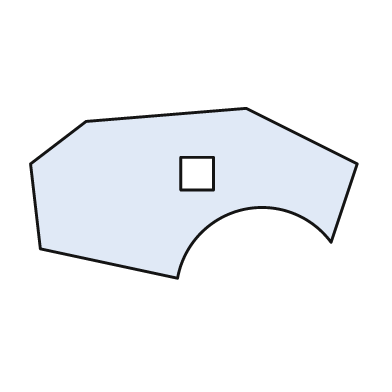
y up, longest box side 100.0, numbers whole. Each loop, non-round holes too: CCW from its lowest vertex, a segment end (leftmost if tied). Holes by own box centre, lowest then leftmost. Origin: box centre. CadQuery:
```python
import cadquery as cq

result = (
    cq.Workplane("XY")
    .moveTo(-5.0, -26.0)
    .threePointArc((15.0, -5.0), (42.0, -15.0))
    .lineTo(50.0, 9.0)
    .lineTo(16.0, 26.0)
    .lineTo(-33.0, 22.0)
    .lineTo(-50.0, 9.0)
    .lineTo(-47.0, -17.0)
    .close()
    .moveTo(-4.0, 1.0)
    .lineTo(6.0, 1.0)
    .lineTo(6.0, 11.0)
    .lineTo(-4.0, 11.0)
    .close()
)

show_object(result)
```